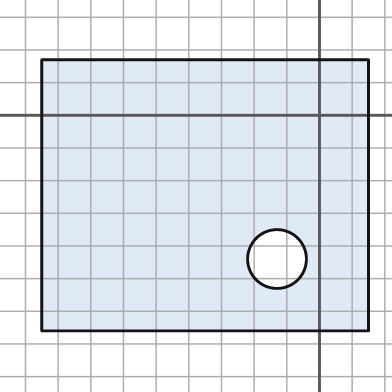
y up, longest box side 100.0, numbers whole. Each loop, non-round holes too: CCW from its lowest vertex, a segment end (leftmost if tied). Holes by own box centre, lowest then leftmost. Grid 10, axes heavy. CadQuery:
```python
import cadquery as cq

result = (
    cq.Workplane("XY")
    .moveTo(-85.0, -66.0)
    .lineTo(15.0, -66.0)
    .lineTo(15.0, 17.0)
    .lineTo(-85.0, 17.0)
    .close()
    .moveTo(-13.0, -44.0)
    .circle(9.0)
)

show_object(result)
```